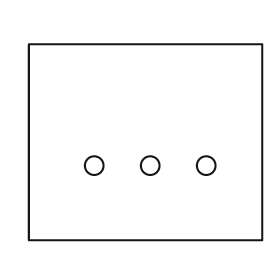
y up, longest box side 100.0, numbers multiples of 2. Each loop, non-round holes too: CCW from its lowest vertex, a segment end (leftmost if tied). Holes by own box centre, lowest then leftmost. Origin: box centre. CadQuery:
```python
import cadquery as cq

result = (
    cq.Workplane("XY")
    .moveTo(-50.0, -42.0)
    .lineTo(50.0, -42.0)
    .lineTo(50.0, 42.0)
    .lineTo(-50.0, 42.0)
    .close()
    .moveTo(-22.0, -10.0)
    .circle(4.0)
    .moveTo(2.0, -10.0)
    .circle(4.0)
    .moveTo(26.0, -10.0)
    .circle(4.0)
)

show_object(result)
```